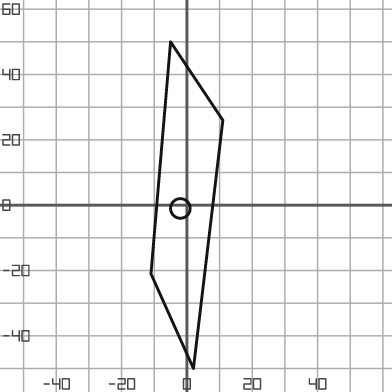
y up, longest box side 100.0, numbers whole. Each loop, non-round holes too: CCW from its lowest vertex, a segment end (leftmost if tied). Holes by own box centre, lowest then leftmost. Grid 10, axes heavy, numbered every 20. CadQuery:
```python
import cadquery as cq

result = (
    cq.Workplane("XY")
    .moveTo(2.0, -50.0)
    .lineTo(11.0, 26.0)
    .lineTo(-5.0, 50.0)
    .lineTo(-11.0, -21.0)
    .close()
    .moveTo(-2.0, -1.0)
    .circle(3.0)
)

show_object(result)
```